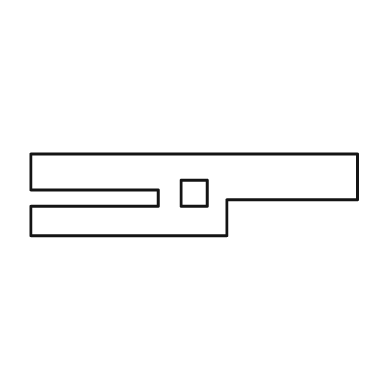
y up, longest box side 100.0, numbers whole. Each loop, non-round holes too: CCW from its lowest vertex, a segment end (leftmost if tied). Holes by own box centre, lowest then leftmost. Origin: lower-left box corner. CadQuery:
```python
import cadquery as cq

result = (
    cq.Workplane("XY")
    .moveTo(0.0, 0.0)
    .lineTo(60.0, 0.0)
    .lineTo(60.0, 11.0)
    .lineTo(100.0, 11.0)
    .lineTo(100.0, 25.0)
    .lineTo(0.0, 25.0)
    .lineTo(0.0, 14.0)
    .lineTo(39.0, 14.0)
    .lineTo(39.0, 9.0)
    .lineTo(0.0, 9.0)
    .close()
    .moveTo(46.0, 9.0)
    .lineTo(54.0, 9.0)
    .lineTo(54.0, 17.0)
    .lineTo(46.0, 17.0)
    .close()
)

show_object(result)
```